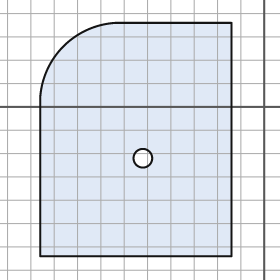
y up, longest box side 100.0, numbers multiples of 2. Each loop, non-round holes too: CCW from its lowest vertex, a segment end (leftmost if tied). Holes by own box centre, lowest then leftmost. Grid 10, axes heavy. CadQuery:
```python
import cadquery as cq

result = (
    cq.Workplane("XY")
    .moveTo(-96.0, -64.0)
    .lineTo(-14.0, -64.0)
    .lineTo(-14.0, 36.0)
    .lineTo(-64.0, 36.0)
    .threePointArc((-86.0, 26.0), (-96.0, 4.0))
    .close()
    .moveTo(-52.0, -22.0)
    .circle(4.0)
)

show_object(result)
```